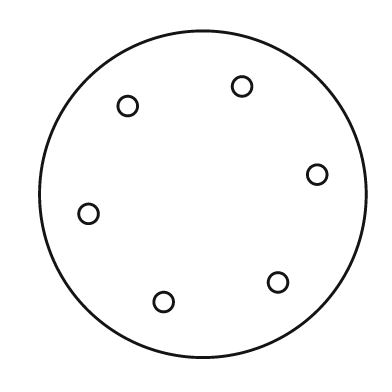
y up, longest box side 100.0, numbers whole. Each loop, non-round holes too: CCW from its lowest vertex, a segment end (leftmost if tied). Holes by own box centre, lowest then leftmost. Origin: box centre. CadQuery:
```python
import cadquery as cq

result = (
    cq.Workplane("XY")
    .moveTo(0.0, 0.0)
    .circle(50.0)
    .moveTo(-12.0, -33.0)
    .circle(3.0)
    .moveTo(23.0, -27.0)
    .circle(3.0)
    .moveTo(-35.0, -6.0)
    .circle(3.0)
    .moveTo(35.0, 6.0)
    .circle(3.0)
    .moveTo(-23.0, 27.0)
    .circle(3.0)
    .moveTo(12.0, 33.0)
    .circle(3.0)
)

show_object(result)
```